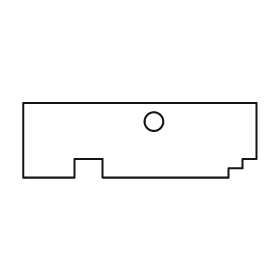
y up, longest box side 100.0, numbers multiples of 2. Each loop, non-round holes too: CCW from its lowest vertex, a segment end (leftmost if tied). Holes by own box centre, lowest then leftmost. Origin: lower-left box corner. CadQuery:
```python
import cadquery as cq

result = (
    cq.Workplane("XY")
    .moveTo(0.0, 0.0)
    .lineTo(22.0, 0.0)
    .lineTo(22.0, 8.0)
    .lineTo(34.0, 8.0)
    .lineTo(34.0, 0.0)
    .lineTo(88.0, 0.0)
    .lineTo(88.0, 4.0)
    .lineTo(94.0, 4.0)
    .lineTo(94.0, 8.0)
    .lineTo(100.0, 8.0)
    .lineTo(100.0, 32.0)
    .lineTo(0.0, 32.0)
    .close()
    .moveTo(56.0, 24.0)
    .circle(4.0)
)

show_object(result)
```